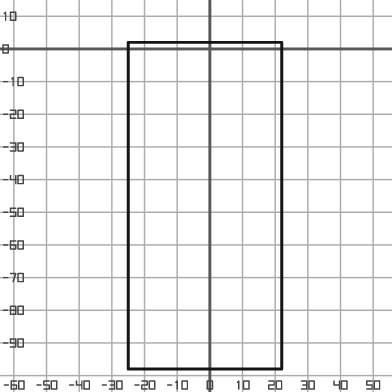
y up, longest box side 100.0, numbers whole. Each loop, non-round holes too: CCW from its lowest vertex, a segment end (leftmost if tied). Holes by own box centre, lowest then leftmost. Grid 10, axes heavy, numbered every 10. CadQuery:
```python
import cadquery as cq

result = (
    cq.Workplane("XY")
    .moveTo(-25.0, -98.0)
    .lineTo(22.0, -98.0)
    .lineTo(22.0, 2.0)
    .lineTo(-25.0, 2.0)
    .close()
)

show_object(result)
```